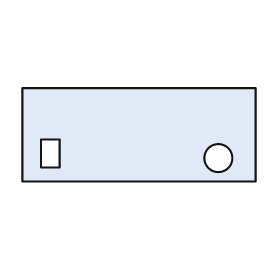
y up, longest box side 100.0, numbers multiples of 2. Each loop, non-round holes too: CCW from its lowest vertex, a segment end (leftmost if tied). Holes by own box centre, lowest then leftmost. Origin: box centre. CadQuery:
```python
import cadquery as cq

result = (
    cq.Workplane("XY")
    .moveTo(-50.0, -20.0)
    .lineTo(50.0, -20.0)
    .lineTo(50.0, 20.0)
    .lineTo(-50.0, 20.0)
    .close()
    .moveTo(34.0, -10.0)
    .circle(6.0)
    .moveTo(-42.0, -14.0)
    .lineTo(-34.0, -14.0)
    .lineTo(-34.0, -2.0)
    .lineTo(-42.0, -2.0)
    .close()
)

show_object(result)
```